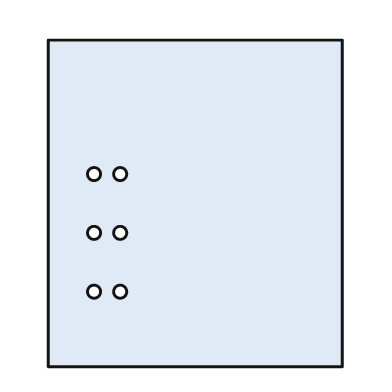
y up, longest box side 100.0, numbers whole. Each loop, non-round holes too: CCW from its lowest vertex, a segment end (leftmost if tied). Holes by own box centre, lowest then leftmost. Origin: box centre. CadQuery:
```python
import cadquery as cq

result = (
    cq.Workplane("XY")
    .moveTo(-45.0, -50.0)
    .lineTo(45.0, -50.0)
    .lineTo(45.0, 50.0)
    .lineTo(-45.0, 50.0)
    .close()
    .moveTo(-31.0, -27.0)
    .circle(2.0)
    .moveTo(-23.0, -27.0)
    .circle(2.0)
    .moveTo(-31.0, -9.0)
    .circle(2.0)
    .moveTo(-23.0, -9.0)
    .circle(2.0)
    .moveTo(-31.0, 9.0)
    .circle(2.0)
    .moveTo(-23.0, 9.0)
    .circle(2.0)
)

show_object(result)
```